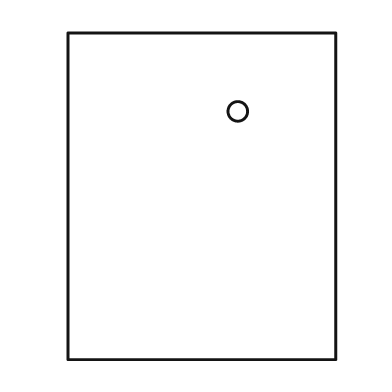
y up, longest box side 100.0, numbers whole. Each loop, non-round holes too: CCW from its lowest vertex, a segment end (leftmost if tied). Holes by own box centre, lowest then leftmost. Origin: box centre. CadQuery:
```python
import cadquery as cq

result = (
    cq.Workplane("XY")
    .moveTo(-41.0, -50.0)
    .lineTo(41.0, -50.0)
    .lineTo(41.0, 50.0)
    .lineTo(-41.0, 50.0)
    .close()
    .moveTo(11.0, 26.0)
    .circle(3.0)
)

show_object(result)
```